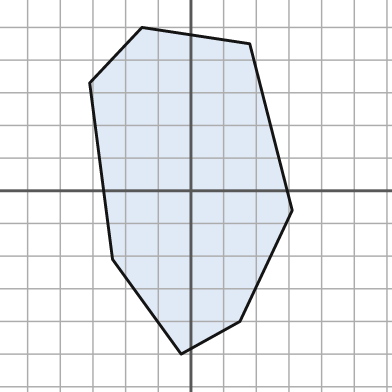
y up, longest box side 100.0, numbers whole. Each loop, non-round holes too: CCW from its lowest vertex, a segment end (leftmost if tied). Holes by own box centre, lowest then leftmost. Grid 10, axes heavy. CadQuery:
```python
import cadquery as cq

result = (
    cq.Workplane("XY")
    .moveTo(-3.0, -50.0)
    .lineTo(15.0, -40.0)
    .lineTo(31.0, -6.0)
    .lineTo(18.0, 45.0)
    .lineTo(-15.0, 50.0)
    .lineTo(-31.0, 33.0)
    .lineTo(-24.0, -21.0)
    .close()
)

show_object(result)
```